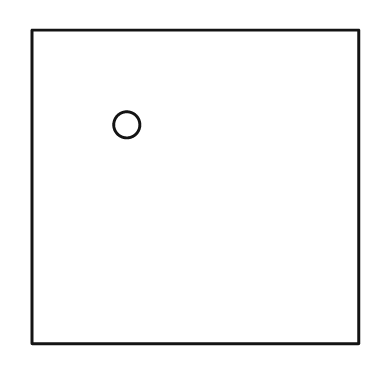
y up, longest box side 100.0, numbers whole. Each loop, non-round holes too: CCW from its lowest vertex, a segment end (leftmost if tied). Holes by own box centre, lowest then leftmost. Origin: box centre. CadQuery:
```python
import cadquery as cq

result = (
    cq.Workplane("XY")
    .moveTo(-50.0, -48.0)
    .lineTo(50.0, -48.0)
    .lineTo(50.0, 48.0)
    .lineTo(-50.0, 48.0)
    .close()
    .moveTo(-21.0, 19.0)
    .circle(4.0)
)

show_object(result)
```